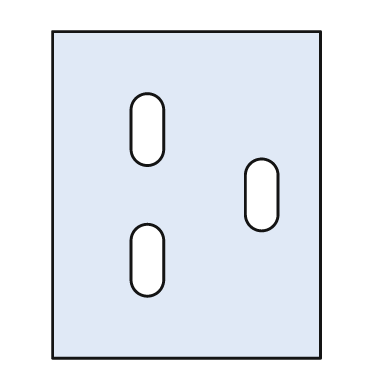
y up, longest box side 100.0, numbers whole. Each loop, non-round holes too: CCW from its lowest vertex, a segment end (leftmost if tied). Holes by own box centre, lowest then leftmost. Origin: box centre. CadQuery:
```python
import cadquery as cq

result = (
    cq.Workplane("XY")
    .moveTo(-41.0, -50.0)
    .lineTo(41.0, -50.0)
    .lineTo(41.0, 50.0)
    .lineTo(-41.0, 50.0)
    .close()
    .moveTo(-17.0, -26.0)
    .threePointArc((-12.0, -31.0), (-7.0, -26.0))
    .lineTo(-7.0, -14.0)
    .threePointArc((-12.0, -9.0), (-17.0, -14.0))
    .close()
    .moveTo(18.0, -6.0)
    .threePointArc((23.0, -11.0), (28.0, -6.0))
    .lineTo(28.0, 6.0)
    .threePointArc((23.0, 11.0), (18.0, 6.0))
    .close()
    .moveTo(-17.0, 14.0)
    .threePointArc((-12.0, 9.0), (-7.0, 14.0))
    .lineTo(-7.0, 26.0)
    .threePointArc((-12.0, 31.0), (-17.0, 26.0))
    .close()
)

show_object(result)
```